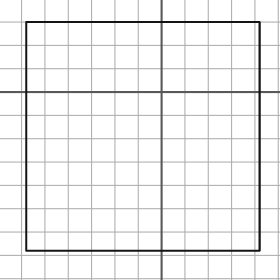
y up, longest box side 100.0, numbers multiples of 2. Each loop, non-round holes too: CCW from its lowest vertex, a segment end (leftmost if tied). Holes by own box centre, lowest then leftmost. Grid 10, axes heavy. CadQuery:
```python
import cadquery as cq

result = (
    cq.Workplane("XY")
    .moveTo(-58.0, -68.0)
    .lineTo(42.0, -68.0)
    .lineTo(42.0, 30.0)
    .lineTo(-58.0, 30.0)
    .close()
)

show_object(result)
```